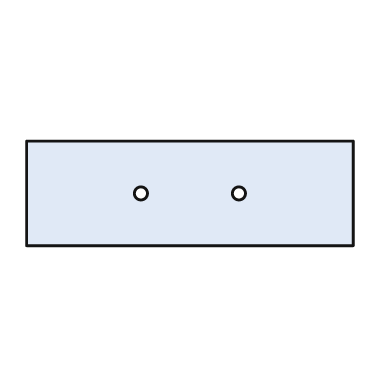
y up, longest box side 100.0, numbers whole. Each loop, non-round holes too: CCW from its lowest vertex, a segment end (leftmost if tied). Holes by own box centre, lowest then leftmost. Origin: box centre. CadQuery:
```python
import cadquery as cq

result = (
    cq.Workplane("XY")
    .moveTo(-50.0, -16.0)
    .lineTo(50.0, -16.0)
    .lineTo(50.0, 16.0)
    .lineTo(-50.0, 16.0)
    .close()
    .moveTo(-15.0, 0.0)
    .circle(2.0)
    .moveTo(15.0, 0.0)
    .circle(2.0)
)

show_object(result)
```